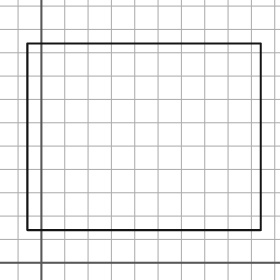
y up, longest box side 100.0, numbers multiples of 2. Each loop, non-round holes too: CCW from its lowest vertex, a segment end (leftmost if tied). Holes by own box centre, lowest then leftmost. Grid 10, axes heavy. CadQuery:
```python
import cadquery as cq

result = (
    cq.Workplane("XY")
    .moveTo(-6.0, 14.0)
    .lineTo(94.0, 14.0)
    .lineTo(94.0, 94.0)
    .lineTo(-6.0, 94.0)
    .close()
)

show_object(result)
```